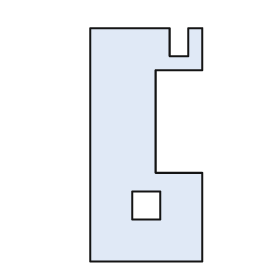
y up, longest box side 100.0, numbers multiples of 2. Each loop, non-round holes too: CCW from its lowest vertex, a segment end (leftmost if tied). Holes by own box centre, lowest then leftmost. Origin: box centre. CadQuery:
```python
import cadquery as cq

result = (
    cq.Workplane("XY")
    .moveTo(-24.0, -50.0)
    .lineTo(24.0, -50.0)
    .lineTo(24.0, -12.0)
    .lineTo(4.0, -12.0)
    .lineTo(4.0, 32.0)
    .lineTo(24.0, 32.0)
    .lineTo(24.0, 50.0)
    .lineTo(18.0, 50.0)
    .lineTo(18.0, 38.0)
    .lineTo(10.0, 38.0)
    .lineTo(10.0, 50.0)
    .lineTo(-24.0, 50.0)
    .close()
    .moveTo(-6.0, -32.0)
    .lineTo(6.0, -32.0)
    .lineTo(6.0, -20.0)
    .lineTo(-6.0, -20.0)
    .close()
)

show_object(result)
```